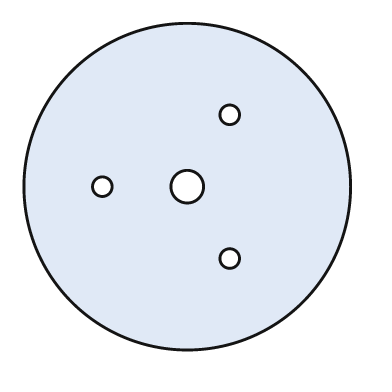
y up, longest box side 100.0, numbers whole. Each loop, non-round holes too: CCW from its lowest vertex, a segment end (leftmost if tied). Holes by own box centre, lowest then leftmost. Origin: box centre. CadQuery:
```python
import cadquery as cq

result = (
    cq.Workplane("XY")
    .moveTo(0.0, 0.0)
    .circle(50.0)
    .moveTo(13.0, -22.0)
    .circle(3.0)
    .moveTo(-26.0, 0.0)
    .circle(3.0)
    .moveTo(0.0, 0.0)
    .circle(5.0)
    .moveTo(13.0, 22.0)
    .circle(3.0)
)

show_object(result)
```